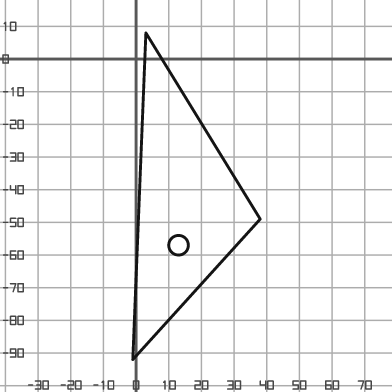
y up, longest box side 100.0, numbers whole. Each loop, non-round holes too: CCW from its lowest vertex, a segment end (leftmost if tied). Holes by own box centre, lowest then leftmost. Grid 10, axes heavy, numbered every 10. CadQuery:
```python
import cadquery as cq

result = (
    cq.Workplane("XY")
    .moveTo(-1.0, -92.0)
    .lineTo(38.0, -49.0)
    .lineTo(3.0, 8.0)
    .close()
    .moveTo(13.0, -57.0)
    .circle(3.0)
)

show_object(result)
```